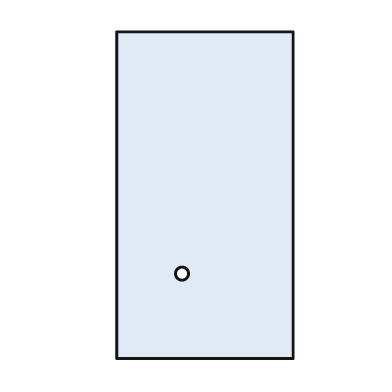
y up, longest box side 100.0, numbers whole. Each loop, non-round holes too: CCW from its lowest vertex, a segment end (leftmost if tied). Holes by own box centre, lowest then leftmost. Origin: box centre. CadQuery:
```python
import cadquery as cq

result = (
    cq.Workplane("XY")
    .moveTo(-27.0, -50.0)
    .lineTo(27.0, -50.0)
    .lineTo(27.0, 50.0)
    .lineTo(-27.0, 50.0)
    .close()
    .moveTo(-7.0, -24.0)
    .circle(2.0)
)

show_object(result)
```